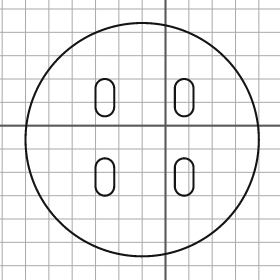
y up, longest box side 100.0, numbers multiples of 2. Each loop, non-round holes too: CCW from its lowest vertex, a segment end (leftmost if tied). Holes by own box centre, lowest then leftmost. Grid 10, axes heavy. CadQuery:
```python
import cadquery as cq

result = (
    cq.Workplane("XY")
    .moveTo(-10.0, -6.0)
    .circle(50.0)
    .moveTo(-30.0, -26.0)
    .threePointArc((-26.0, -30.0), (-22.0, -26.0))
    .lineTo(-22.0, -18.0)
    .threePointArc((-26.0, -14.0), (-30.0, -18.0))
    .close()
    .moveTo(4.0, -26.0)
    .threePointArc((8.0, -30.0), (12.0, -26.0))
    .lineTo(12.0, -18.0)
    .threePointArc((8.0, -14.0), (4.0, -18.0))
    .close()
    .moveTo(-30.0, 8.0)
    .threePointArc((-26.0, 4.0), (-22.0, 8.0))
    .lineTo(-22.0, 16.0)
    .threePointArc((-26.0, 20.0), (-30.0, 16.0))
    .close()
    .moveTo(4.0, 8.0)
    .threePointArc((8.0, 4.0), (12.0, 8.0))
    .lineTo(12.0, 16.0)
    .threePointArc((8.0, 20.0), (4.0, 16.0))
    .close()
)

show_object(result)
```